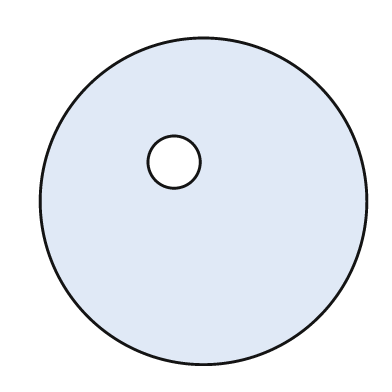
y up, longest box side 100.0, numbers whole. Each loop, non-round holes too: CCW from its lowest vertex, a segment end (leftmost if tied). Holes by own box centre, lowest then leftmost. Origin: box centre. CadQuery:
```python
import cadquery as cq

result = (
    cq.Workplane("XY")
    .moveTo(0.0, 0.0)
    .circle(50.0)
    .moveTo(-9.0, 12.0)
    .circle(8.0)
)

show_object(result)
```